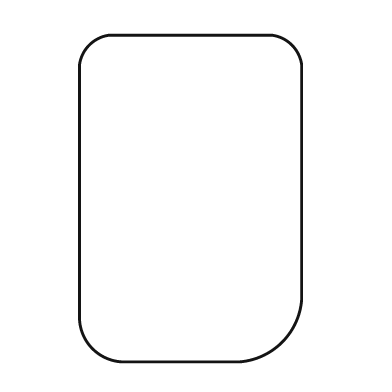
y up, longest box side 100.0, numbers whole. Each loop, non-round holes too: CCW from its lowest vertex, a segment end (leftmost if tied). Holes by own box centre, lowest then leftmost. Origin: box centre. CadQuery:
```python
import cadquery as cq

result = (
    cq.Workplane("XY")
    .moveTo(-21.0, -50.0)
    .lineTo(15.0, -50.0)
    .threePointArc((28.0, -44.0), (34.0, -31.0))
    .lineTo(34.0, 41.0)
    .threePointArc((31.0, 47.0), (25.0, 50.0))
    .lineTo(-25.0, 50.0)
    .threePointArc((-31.0, 47.0), (-34.0, 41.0))
    .lineTo(-34.0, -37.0)
    .threePointArc((-30.0, -46.0), (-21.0, -50.0))
    .close()
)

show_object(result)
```